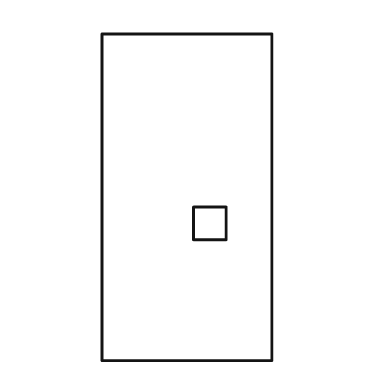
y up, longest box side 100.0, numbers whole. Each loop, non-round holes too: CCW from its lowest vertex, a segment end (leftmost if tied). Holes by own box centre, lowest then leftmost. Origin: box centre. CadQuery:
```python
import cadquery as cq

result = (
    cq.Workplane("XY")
    .moveTo(-26.0, -50.0)
    .lineTo(26.0, -50.0)
    .lineTo(26.0, 50.0)
    .lineTo(-26.0, 50.0)
    .close()
    .moveTo(2.0, -13.0)
    .lineTo(12.0, -13.0)
    .lineTo(12.0, -3.0)
    .lineTo(2.0, -3.0)
    .close()
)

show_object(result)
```